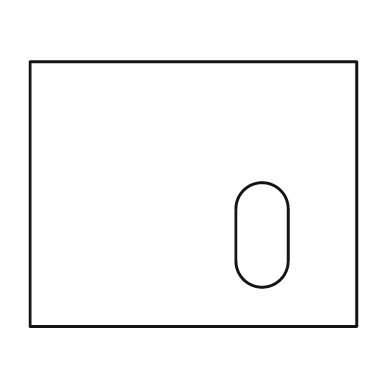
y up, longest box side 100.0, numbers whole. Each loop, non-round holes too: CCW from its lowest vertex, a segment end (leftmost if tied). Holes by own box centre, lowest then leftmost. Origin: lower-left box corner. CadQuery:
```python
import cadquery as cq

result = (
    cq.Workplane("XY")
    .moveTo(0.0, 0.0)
    .lineTo(100.0, 0.0)
    .lineTo(100.0, 81.0)
    .lineTo(0.0, 81.0)
    .close()
    .moveTo(63.0, 20.0)
    .threePointArc((71.0, 12.0), (79.0, 20.0))
    .lineTo(79.0, 36.0)
    .threePointArc((71.0, 44.0), (63.0, 36.0))
    .close()
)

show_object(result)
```